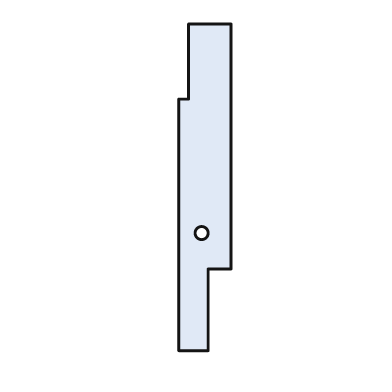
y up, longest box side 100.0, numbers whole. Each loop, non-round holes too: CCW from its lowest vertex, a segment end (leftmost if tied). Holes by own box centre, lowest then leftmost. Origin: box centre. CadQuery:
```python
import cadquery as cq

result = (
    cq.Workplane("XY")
    .moveTo(-8.0, -50.0)
    .lineTo(1.0, -50.0)
    .lineTo(1.0, -25.0)
    .lineTo(8.0, -25.0)
    .lineTo(8.0, 50.0)
    .lineTo(-5.0, 50.0)
    .lineTo(-5.0, 27.0)
    .lineTo(-8.0, 27.0)
    .close()
    .moveTo(-1.0, -14.0)
    .circle(2.0)
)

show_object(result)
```